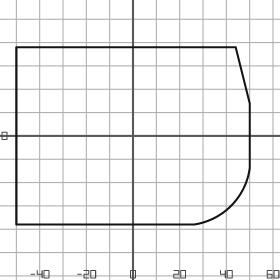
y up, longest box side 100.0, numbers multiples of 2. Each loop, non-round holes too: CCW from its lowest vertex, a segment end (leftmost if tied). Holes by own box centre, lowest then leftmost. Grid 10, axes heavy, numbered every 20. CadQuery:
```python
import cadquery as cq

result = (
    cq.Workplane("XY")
    .moveTo(-50.0, -38.0)
    .lineTo(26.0, -38.0)
    .threePointArc((42.0, -30.0), (50.0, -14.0))
    .lineTo(50.0, 14.0)
    .lineTo(44.0, 38.0)
    .lineTo(-50.0, 38.0)
    .close()
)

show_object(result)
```